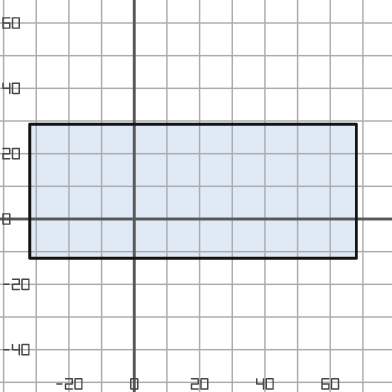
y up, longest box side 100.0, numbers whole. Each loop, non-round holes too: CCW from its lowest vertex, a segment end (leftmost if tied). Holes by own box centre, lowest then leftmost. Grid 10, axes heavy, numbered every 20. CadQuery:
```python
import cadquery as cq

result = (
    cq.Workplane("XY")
    .moveTo(-32.0, -12.0)
    .lineTo(68.0, -12.0)
    .lineTo(68.0, 29.0)
    .lineTo(-32.0, 29.0)
    .close()
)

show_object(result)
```